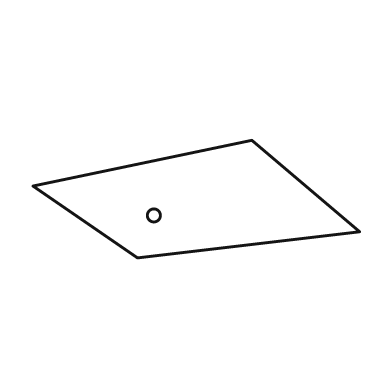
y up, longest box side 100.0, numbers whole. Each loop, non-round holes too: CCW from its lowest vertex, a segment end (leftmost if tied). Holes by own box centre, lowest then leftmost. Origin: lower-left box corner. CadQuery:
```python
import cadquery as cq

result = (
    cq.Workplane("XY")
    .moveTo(32.0, 0.0)
    .lineTo(100.0, 8.0)
    .lineTo(67.0, 36.0)
    .lineTo(0.0, 22.0)
    .close()
    .moveTo(37.0, 13.0)
    .circle(2.0)
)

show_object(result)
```